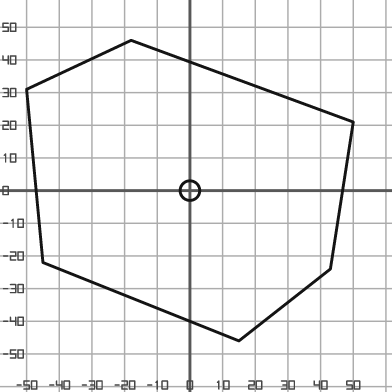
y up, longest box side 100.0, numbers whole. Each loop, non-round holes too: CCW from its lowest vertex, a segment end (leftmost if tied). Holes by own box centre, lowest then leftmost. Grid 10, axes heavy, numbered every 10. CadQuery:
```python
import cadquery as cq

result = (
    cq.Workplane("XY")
    .moveTo(15.0, -46.0)
    .lineTo(43.0, -24.0)
    .lineTo(50.0, 21.0)
    .lineTo(-18.0, 46.0)
    .lineTo(-50.0, 31.0)
    .lineTo(-45.0, -22.0)
    .close()
    .moveTo(0.0, 0.0)
    .circle(3.0)
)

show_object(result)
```